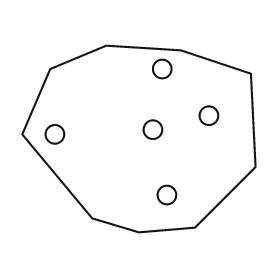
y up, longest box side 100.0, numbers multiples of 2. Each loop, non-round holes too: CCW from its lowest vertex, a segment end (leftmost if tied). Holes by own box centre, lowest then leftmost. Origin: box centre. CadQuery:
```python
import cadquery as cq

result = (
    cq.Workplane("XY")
    .moveTo(0.0, -40.0)
    .lineTo(24.0, -38.0)
    .lineTo(50.0, -12.0)
    .lineTo(48.0, 28.0)
    .lineTo(18.0, 38.0)
    .lineTo(-14.0, 40.0)
    .lineTo(-38.0, 30.0)
    .lineTo(-50.0, 2.0)
    .lineTo(-20.0, -34.0)
    .close()
    .moveTo(12.0, -24.0)
    .circle(4.0)
    .moveTo(-36.0, 2.0)
    .circle(4.0)
    .moveTo(6.0, 4.0)
    .circle(4.0)
    .moveTo(30.0, 10.0)
    .circle(4.0)
    .moveTo(10.0, 30.0)
    .circle(4.0)
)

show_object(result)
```